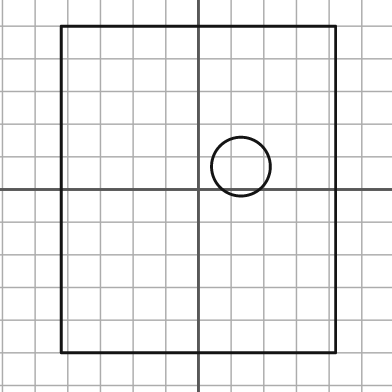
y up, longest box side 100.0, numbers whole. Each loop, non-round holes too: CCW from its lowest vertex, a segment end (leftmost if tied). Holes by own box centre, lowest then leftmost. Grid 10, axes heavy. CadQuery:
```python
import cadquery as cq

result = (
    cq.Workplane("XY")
    .moveTo(-42.0, -50.0)
    .lineTo(42.0, -50.0)
    .lineTo(42.0, 50.0)
    .lineTo(-42.0, 50.0)
    .close()
    .moveTo(13.0, 7.0)
    .circle(9.0)
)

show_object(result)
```